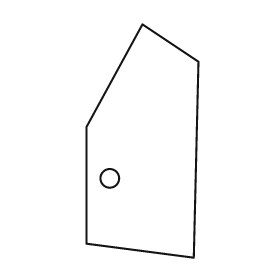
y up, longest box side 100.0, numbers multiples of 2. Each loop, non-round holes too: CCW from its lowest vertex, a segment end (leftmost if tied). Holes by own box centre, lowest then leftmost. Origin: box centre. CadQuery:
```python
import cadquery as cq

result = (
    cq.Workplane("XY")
    .moveTo(22.0, -50.0)
    .lineTo(24.0, 34.0)
    .lineTo(0.0, 50.0)
    .lineTo(-24.0, 6.0)
    .lineTo(-24.0, -44.0)
    .close()
    .moveTo(-14.0, -16.0)
    .circle(4.0)
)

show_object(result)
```